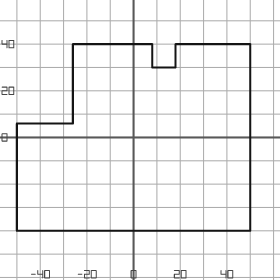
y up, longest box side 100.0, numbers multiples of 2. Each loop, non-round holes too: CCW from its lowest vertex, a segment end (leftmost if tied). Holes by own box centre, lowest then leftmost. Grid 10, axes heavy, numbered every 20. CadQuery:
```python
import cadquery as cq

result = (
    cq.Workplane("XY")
    .moveTo(-50.0, -40.0)
    .lineTo(50.0, -40.0)
    .lineTo(50.0, 40.0)
    .lineTo(18.0, 40.0)
    .lineTo(18.0, 30.0)
    .lineTo(8.0, 30.0)
    .lineTo(8.0, 40.0)
    .lineTo(-26.0, 40.0)
    .lineTo(-26.0, 6.0)
    .lineTo(-50.0, 6.0)
    .close()
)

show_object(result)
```